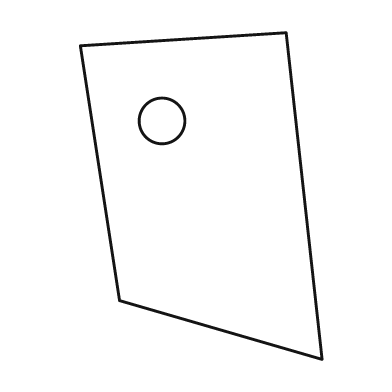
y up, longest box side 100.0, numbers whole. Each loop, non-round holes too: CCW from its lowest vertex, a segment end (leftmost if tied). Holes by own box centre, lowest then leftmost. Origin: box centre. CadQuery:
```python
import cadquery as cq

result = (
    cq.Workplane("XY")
    .moveTo(37.0, -50.0)
    .lineTo(26.0, 50.0)
    .lineTo(-37.0, 46.0)
    .lineTo(-25.0, -32.0)
    .close()
    .moveTo(-12.0, 23.0)
    .circle(7.0)
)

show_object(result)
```